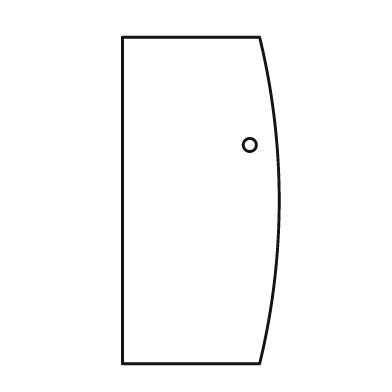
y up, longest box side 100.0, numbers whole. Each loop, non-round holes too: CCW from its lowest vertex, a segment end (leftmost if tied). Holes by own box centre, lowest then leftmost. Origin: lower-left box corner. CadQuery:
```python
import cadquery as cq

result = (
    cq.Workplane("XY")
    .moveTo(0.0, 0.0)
    .lineTo(42.0, 0.0)
    .threePointArc((48.0, 50.0), (42.0, 100.0))
    .lineTo(0.0, 100.0)
    .close()
    .moveTo(39.0, 67.0)
    .circle(2.0)
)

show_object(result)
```